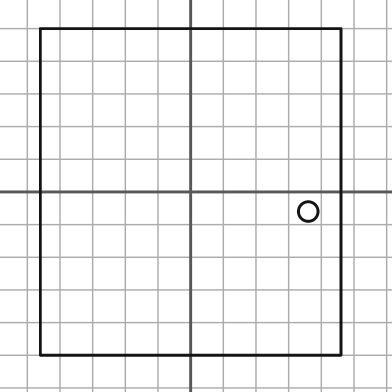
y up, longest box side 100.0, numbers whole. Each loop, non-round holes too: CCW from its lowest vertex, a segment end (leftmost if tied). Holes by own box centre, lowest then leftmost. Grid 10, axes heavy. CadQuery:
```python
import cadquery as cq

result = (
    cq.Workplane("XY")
    .moveTo(-46.0, -50.0)
    .lineTo(46.0, -50.0)
    .lineTo(46.0, 50.0)
    .lineTo(-46.0, 50.0)
    .close()
    .moveTo(36.0, -6.0)
    .circle(3.0)
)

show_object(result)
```